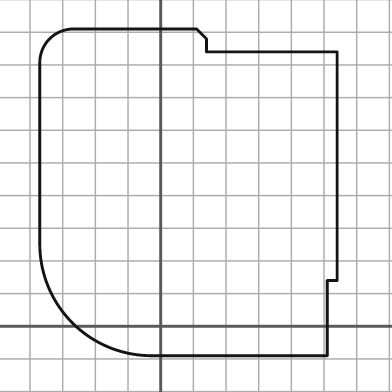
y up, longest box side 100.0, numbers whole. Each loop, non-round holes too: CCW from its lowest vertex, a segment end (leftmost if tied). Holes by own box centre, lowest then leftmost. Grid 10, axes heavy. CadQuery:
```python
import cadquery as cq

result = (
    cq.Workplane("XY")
    .moveTo(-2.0, -9.0)
    .lineTo(51.0, -9.0)
    .lineTo(51.0, 14.0)
    .lineTo(54.0, 14.0)
    .lineTo(54.0, 84.0)
    .lineTo(14.0, 84.0)
    .lineTo(14.0, 88.0)
    .lineTo(11.0, 91.0)
    .lineTo(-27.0, 91.0)
    .threePointArc((-34.0, 88.0), (-37.0, 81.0))
    .lineTo(-37.0, 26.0)
    .threePointArc((-27.0, 1.0), (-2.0, -9.0))
    .close()
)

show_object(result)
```